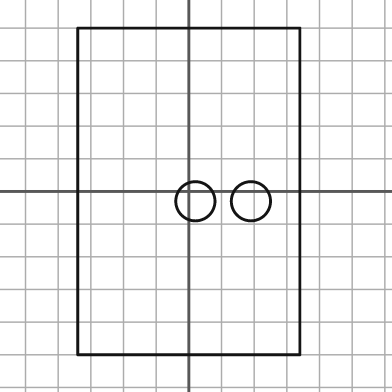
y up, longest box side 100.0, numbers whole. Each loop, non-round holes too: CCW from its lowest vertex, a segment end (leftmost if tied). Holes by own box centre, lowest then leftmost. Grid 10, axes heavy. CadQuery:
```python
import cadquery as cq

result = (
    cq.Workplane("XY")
    .moveTo(-34.0, -50.0)
    .lineTo(34.0, -50.0)
    .lineTo(34.0, 50.0)
    .lineTo(-34.0, 50.0)
    .close()
    .moveTo(2.0, -3.0)
    .circle(6.0)
    .moveTo(19.0, -3.0)
    .circle(6.0)
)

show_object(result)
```